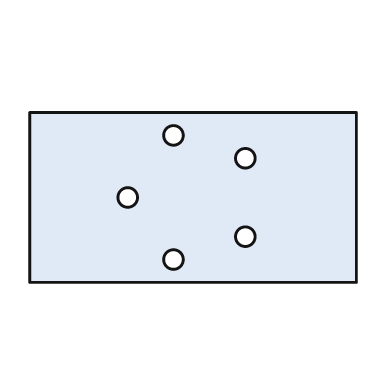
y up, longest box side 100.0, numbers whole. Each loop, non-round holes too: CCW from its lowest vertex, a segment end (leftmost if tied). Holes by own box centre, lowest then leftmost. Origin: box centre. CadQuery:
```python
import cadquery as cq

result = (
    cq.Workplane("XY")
    .moveTo(-50.0, -26.0)
    .lineTo(50.0, -26.0)
    .lineTo(50.0, 26.0)
    .lineTo(-50.0, 26.0)
    .close()
    .moveTo(-6.0, -19.0)
    .circle(3.0)
    .moveTo(16.0, -12.0)
    .circle(3.0)
    .moveTo(-20.0, 0.0)
    .circle(3.0)
    .moveTo(16.0, 12.0)
    .circle(3.0)
    .moveTo(-6.0, 19.0)
    .circle(3.0)
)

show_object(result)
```